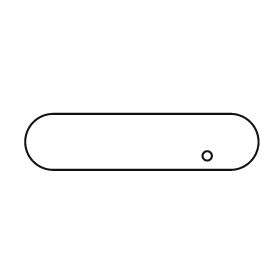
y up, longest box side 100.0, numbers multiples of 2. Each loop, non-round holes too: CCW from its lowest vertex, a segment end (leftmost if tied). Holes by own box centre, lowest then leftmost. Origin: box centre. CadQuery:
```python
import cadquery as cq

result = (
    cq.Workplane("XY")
    .moveTo(-38.0, -12.0)
    .lineTo(38.0, -12.0)
    .threePointArc((50.0, 0.0), (38.0, 12.0))
    .lineTo(-38.0, 12.0)
    .threePointArc((-50.0, 0.0), (-38.0, -12.0))
    .close()
    .moveTo(28.0, -6.0)
    .circle(2.0)
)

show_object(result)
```